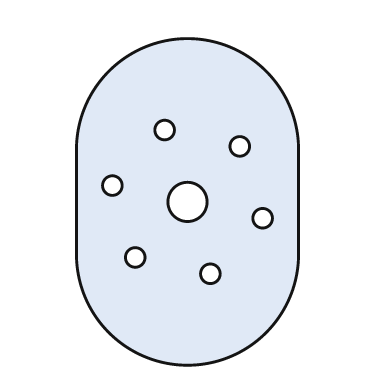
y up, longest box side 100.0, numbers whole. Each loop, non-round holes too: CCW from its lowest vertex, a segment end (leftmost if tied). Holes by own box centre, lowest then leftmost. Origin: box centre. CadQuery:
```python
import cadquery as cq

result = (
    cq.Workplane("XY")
    .moveTo(-34.0, -16.0)
    .threePointArc((0.0, -50.0), (34.0, -16.0))
    .lineTo(34.0, 16.0)
    .threePointArc((0.0, 50.0), (-34.0, 16.0))
    .close()
    .moveTo(7.0, -22.0)
    .circle(3.0)
    .moveTo(-16.0, -17.0)
    .circle(3.0)
    .moveTo(23.0, -5.0)
    .circle(3.0)
    .moveTo(0.0, 0.0)
    .circle(6.0)
    .moveTo(-23.0, 5.0)
    .circle(3.0)
    .moveTo(16.0, 17.0)
    .circle(3.0)
    .moveTo(-7.0, 22.0)
    .circle(3.0)
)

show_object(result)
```